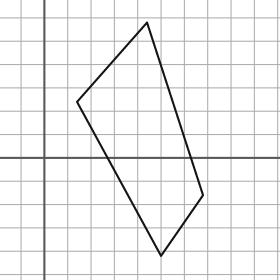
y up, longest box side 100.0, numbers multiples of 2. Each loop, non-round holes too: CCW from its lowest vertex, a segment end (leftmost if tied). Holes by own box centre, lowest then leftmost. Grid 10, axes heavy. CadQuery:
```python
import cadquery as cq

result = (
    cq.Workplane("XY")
    .moveTo(50.0, -42.0)
    .lineTo(68.0, -16.0)
    .lineTo(44.0, 58.0)
    .lineTo(14.0, 24.0)
    .close()
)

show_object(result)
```